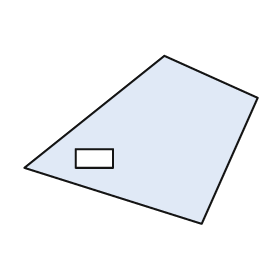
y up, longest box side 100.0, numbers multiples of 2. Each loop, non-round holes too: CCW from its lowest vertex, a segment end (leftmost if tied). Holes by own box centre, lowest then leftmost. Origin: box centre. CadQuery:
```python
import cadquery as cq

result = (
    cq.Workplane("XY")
    .moveTo(26.0, -36.0)
    .lineTo(50.0, 18.0)
    .lineTo(10.0, 36.0)
    .lineTo(-50.0, -12.0)
    .close()
    .moveTo(-28.0, -12.0)
    .lineTo(-12.0, -12.0)
    .lineTo(-12.0, -4.0)
    .lineTo(-28.0, -4.0)
    .close()
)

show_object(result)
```